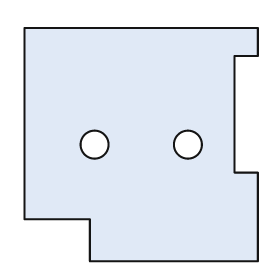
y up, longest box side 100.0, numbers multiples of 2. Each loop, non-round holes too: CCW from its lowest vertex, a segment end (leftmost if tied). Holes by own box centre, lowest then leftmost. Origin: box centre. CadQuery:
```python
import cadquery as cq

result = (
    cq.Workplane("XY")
    .moveTo(-22.0, -50.0)
    .lineTo(50.0, -50.0)
    .lineTo(50.0, -12.0)
    .lineTo(40.0, -12.0)
    .lineTo(40.0, 38.0)
    .lineTo(50.0, 38.0)
    .lineTo(50.0, 50.0)
    .lineTo(-50.0, 50.0)
    .lineTo(-50.0, -32.0)
    .lineTo(-22.0, -32.0)
    .close()
    .moveTo(-20.0, 0.0)
    .circle(6.0)
    .moveTo(20.0, 0.0)
    .circle(6.0)
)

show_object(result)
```